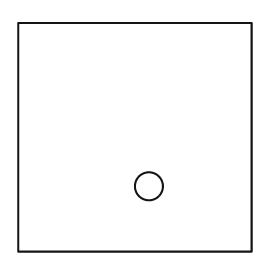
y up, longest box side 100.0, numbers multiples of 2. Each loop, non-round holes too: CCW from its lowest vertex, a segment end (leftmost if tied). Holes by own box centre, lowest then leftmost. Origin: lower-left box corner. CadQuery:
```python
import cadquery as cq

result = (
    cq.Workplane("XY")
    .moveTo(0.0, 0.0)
    .lineTo(100.0, 0.0)
    .lineTo(100.0, 98.0)
    .lineTo(0.0, 98.0)
    .close()
    .moveTo(56.0, 28.0)
    .circle(6.0)
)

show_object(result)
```